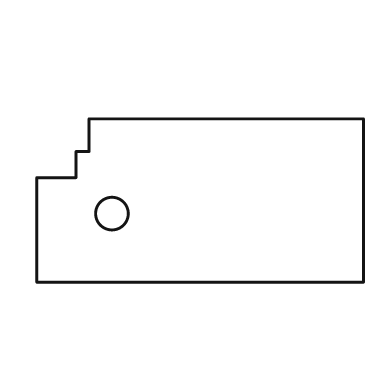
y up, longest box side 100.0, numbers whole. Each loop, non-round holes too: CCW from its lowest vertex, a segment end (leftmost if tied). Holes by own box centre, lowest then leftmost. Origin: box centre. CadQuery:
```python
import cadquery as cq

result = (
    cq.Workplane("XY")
    .moveTo(-50.0, -25.0)
    .lineTo(50.0, -25.0)
    .lineTo(50.0, 25.0)
    .lineTo(-34.0, 25.0)
    .lineTo(-34.0, 15.0)
    .lineTo(-38.0, 15.0)
    .lineTo(-38.0, 7.0)
    .lineTo(-50.0, 7.0)
    .close()
    .moveTo(-27.0, -4.0)
    .circle(5.0)
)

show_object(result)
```